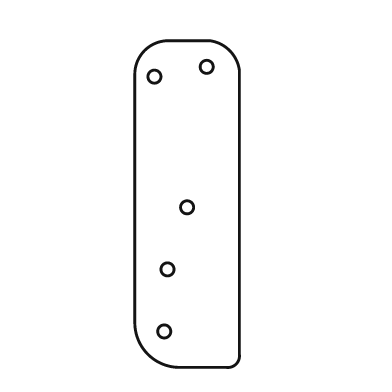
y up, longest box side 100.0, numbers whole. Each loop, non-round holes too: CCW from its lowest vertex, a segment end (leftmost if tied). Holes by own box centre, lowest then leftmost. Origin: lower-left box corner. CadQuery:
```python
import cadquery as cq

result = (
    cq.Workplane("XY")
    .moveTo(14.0, 0.0)
    .lineTo(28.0, 0.0)
    .threePointArc((31.0, 1.0), (32.0, 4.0))
    .lineTo(32.0, 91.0)
    .threePointArc((29.0, 97.0), (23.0, 100.0))
    .lineTo(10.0, 100.0)
    .threePointArc((3.0, 97.0), (0.0, 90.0))
    .lineTo(0.0, 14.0)
    .threePointArc((4.0, 4.0), (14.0, 0.0))
    .close()
    .moveTo(9.0, 11.0)
    .circle(2.0)
    .moveTo(10.0, 30.0)
    .circle(2.0)
    .moveTo(16.0, 49.0)
    .circle(2.0)
    .moveTo(6.0, 89.0)
    .circle(2.0)
    .moveTo(22.0, 92.0)
    .circle(2.0)
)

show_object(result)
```